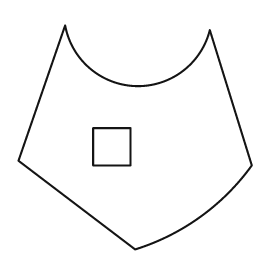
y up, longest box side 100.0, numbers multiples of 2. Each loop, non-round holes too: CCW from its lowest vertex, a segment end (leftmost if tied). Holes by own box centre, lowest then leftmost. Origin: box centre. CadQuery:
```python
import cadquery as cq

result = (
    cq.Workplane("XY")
    .moveTo(0.0, -48.0)
    .threePointArc((28.0, -34.0), (50.0, -12.0))
    .lineTo(32.0, 46.0)
    .threePointArc((0.0, 22.0), (-30.0, 48.0))
    .lineTo(-50.0, -10.0)
    .close()
    .moveTo(-18.0, -12.0)
    .lineTo(-2.0, -12.0)
    .lineTo(-2.0, 4.0)
    .lineTo(-18.0, 4.0)
    .close()
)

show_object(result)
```